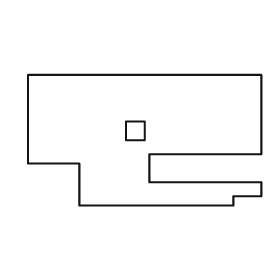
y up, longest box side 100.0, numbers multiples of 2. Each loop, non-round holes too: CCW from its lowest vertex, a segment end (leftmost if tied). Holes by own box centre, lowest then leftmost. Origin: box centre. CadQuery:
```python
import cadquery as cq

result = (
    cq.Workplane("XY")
    .moveTo(-28.0, -28.0)
    .lineTo(38.0, -28.0)
    .lineTo(38.0, -24.0)
    .lineTo(50.0, -24.0)
    .lineTo(50.0, -18.0)
    .lineTo(2.0, -18.0)
    .lineTo(2.0, -6.0)
    .lineTo(50.0, -6.0)
    .lineTo(50.0, 28.0)
    .lineTo(-50.0, 28.0)
    .lineTo(-50.0, -10.0)
    .lineTo(-28.0, -10.0)
    .close()
    .moveTo(-8.0, 0.0)
    .lineTo(0.0, 0.0)
    .lineTo(0.0, 8.0)
    .lineTo(-8.0, 8.0)
    .close()
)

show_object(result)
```